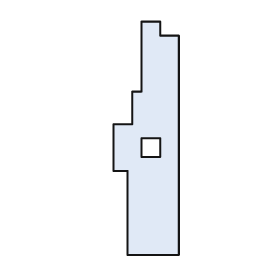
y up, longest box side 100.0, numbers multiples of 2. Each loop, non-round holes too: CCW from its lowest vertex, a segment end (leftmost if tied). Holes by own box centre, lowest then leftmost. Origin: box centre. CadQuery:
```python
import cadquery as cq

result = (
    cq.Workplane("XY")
    .moveTo(-8.0, -50.0)
    .lineTo(14.0, -50.0)
    .lineTo(14.0, 44.0)
    .lineTo(6.0, 44.0)
    .lineTo(6.0, 50.0)
    .lineTo(-2.0, 50.0)
    .lineTo(-2.0, 20.0)
    .lineTo(-6.0, 20.0)
    .lineTo(-6.0, 6.0)
    .lineTo(-14.0, 6.0)
    .lineTo(-14.0, -14.0)
    .lineTo(-8.0, -14.0)
    .close()
    .moveTo(-2.0, -8.0)
    .lineTo(6.0, -8.0)
    .lineTo(6.0, 0.0)
    .lineTo(-2.0, 0.0)
    .close()
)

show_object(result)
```